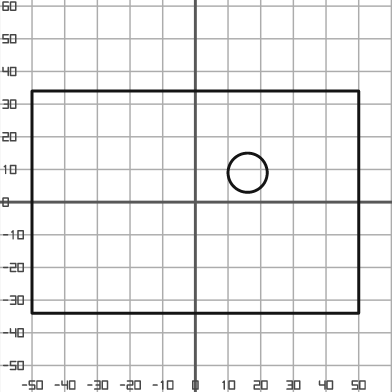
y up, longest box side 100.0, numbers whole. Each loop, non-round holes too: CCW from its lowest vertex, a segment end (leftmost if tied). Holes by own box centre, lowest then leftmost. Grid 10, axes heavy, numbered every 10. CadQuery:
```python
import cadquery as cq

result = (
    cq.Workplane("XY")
    .moveTo(-50.0, -34.0)
    .lineTo(50.0, -34.0)
    .lineTo(50.0, 34.0)
    .lineTo(-50.0, 34.0)
    .close()
    .moveTo(16.0, 9.0)
    .circle(6.0)
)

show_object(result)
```